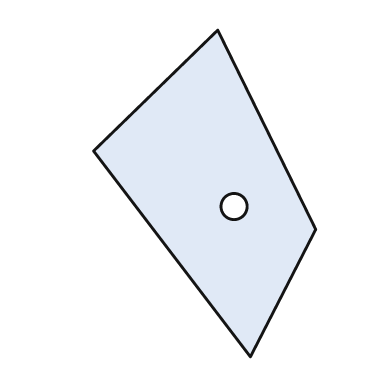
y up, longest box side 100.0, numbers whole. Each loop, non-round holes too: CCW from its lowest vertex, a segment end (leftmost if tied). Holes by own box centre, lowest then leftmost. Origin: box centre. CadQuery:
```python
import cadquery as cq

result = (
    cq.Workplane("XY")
    .moveTo(14.0, -50.0)
    .lineTo(34.0, -11.0)
    .lineTo(4.0, 50.0)
    .lineTo(-34.0, 13.0)
    .close()
    .moveTo(9.0, -4.0)
    .circle(4.0)
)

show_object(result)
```